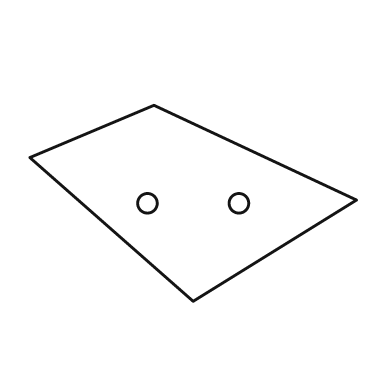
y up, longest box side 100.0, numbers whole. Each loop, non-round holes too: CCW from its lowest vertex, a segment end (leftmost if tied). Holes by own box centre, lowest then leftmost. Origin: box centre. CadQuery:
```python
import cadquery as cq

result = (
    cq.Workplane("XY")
    .moveTo(0.0, -30.0)
    .lineTo(50.0, 1.0)
    .lineTo(-12.0, 30.0)
    .lineTo(-50.0, 14.0)
    .close()
    .moveTo(-14.0, 0.0)
    .circle(3.0)
    .moveTo(14.0, 0.0)
    .circle(3.0)
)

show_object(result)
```